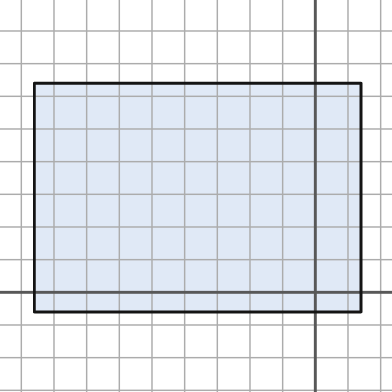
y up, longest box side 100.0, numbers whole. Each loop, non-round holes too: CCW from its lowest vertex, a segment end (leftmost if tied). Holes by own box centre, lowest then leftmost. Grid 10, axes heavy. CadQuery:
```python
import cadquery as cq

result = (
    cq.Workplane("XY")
    .moveTo(-86.0, -6.0)
    .lineTo(14.0, -6.0)
    .lineTo(14.0, 64.0)
    .lineTo(-86.0, 64.0)
    .close()
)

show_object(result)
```